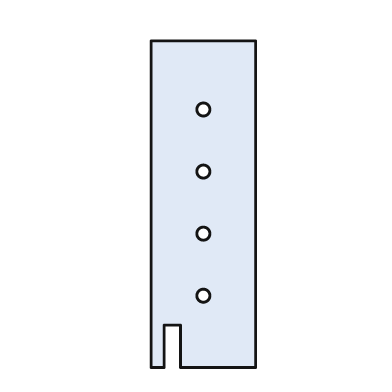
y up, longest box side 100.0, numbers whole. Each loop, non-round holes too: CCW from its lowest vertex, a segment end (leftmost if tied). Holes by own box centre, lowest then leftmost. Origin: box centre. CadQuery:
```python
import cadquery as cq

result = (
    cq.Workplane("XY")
    .moveTo(-16.0, -50.0)
    .lineTo(-12.0, -50.0)
    .lineTo(-12.0, -37.0)
    .lineTo(-7.0, -37.0)
    .lineTo(-7.0, -50.0)
    .lineTo(16.0, -50.0)
    .lineTo(16.0, 50.0)
    .lineTo(-16.0, 50.0)
    .close()
    .moveTo(0.0, -28.0)
    .circle(2.0)
    .moveTo(0.0, -9.0)
    .circle(2.0)
    .moveTo(0.0, 10.0)
    .circle(2.0)
    .moveTo(0.0, 29.0)
    .circle(2.0)
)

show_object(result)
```